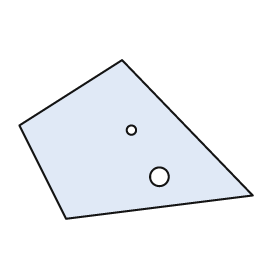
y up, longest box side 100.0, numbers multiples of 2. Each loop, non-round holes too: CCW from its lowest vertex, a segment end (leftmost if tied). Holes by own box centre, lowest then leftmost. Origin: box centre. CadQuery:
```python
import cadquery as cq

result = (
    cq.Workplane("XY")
    .moveTo(-30.0, -34.0)
    .lineTo(50.0, -24.0)
    .lineTo(-6.0, 34.0)
    .lineTo(-50.0, 6.0)
    .close()
    .moveTo(10.0, -16.0)
    .circle(4.0)
    .moveTo(-2.0, 4.0)
    .circle(2.0)
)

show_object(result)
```